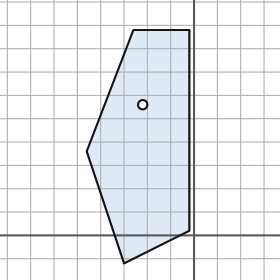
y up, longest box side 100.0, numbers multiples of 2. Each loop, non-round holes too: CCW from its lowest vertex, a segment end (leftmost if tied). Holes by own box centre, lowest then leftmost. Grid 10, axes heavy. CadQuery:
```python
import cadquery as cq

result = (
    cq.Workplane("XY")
    .moveTo(-30.0, -12.0)
    .lineTo(-2.0, 2.0)
    .lineTo(-2.0, 88.0)
    .lineTo(-26.0, 88.0)
    .lineTo(-46.0, 36.0)
    .close()
    .moveTo(-22.0, 56.0)
    .circle(2.0)
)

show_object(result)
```